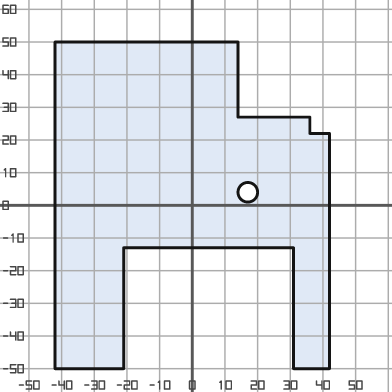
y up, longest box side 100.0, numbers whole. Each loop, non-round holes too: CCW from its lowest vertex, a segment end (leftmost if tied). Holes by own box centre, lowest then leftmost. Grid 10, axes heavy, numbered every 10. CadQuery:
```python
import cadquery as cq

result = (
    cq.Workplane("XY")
    .moveTo(-42.0, -50.0)
    .lineTo(-21.0, -50.0)
    .lineTo(-21.0, -13.0)
    .lineTo(31.0, -13.0)
    .lineTo(31.0, -50.0)
    .lineTo(42.0, -50.0)
    .lineTo(42.0, 22.0)
    .lineTo(36.0, 22.0)
    .lineTo(36.0, 27.0)
    .lineTo(14.0, 27.0)
    .lineTo(14.0, 50.0)
    .lineTo(-42.0, 50.0)
    .close()
    .moveTo(17.0, 4.0)
    .circle(3.0)
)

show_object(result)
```